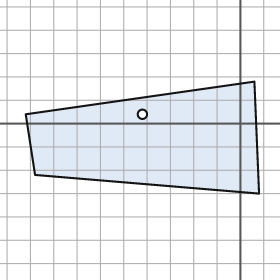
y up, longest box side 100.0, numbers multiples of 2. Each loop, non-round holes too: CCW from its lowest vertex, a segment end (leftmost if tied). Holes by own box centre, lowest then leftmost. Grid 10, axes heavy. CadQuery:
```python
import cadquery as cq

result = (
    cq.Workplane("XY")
    .moveTo(8.0, -30.0)
    .lineTo(6.0, 18.0)
    .lineTo(-92.0, 4.0)
    .lineTo(-88.0, -22.0)
    .close()
    .moveTo(-42.0, 4.0)
    .circle(2.0)
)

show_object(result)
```